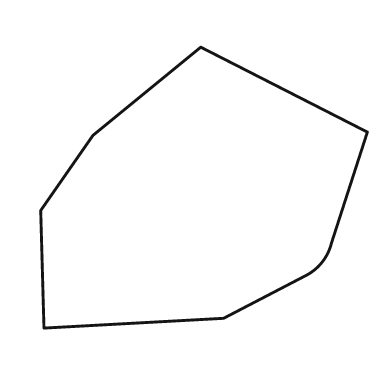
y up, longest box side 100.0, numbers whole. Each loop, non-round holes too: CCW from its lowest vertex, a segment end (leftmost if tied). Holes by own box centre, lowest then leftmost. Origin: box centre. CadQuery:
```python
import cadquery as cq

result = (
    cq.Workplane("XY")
    .moveTo(-49.0, -43.0)
    .lineTo(6.0, -40.0)
    .lineTo(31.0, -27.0)
    .threePointArc((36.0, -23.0), (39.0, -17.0))
    .lineTo(50.0, 17.0)
    .lineTo(-1.0, 43.0)
    .lineTo(-34.0, 16.0)
    .lineTo(-50.0, -7.0)
    .close()
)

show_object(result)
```